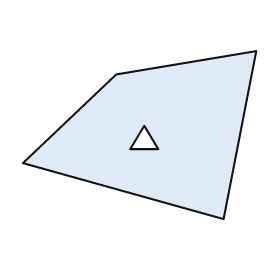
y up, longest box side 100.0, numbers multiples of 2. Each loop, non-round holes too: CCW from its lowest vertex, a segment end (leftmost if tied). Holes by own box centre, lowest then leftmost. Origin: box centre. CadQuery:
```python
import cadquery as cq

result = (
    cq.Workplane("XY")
    .moveTo(36.0, -36.0)
    .lineTo(50.0, 36.0)
    .lineTo(-10.0, 26.0)
    .lineTo(-50.0, -12.0)
    .close()
    .moveTo(-4.0, -6.0)
    .lineTo(8.0, -6.0)
    .lineTo(2.0, 4.0)
    .close()
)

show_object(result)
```